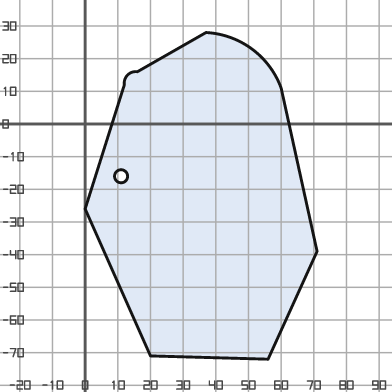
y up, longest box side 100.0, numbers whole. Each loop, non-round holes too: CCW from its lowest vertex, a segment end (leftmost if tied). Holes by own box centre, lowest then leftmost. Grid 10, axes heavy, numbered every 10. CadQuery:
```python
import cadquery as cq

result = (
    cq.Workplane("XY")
    .moveTo(56.0, -72.0)
    .lineTo(71.0, -39.0)
    .lineTo(60.0, 11.0)
    .threePointArc((51.0, 23.0), (37.0, 28.0))
    .lineTo(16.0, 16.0)
    .threePointArc((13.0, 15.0), (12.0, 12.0))
    .lineTo(0.0, -26.0)
    .lineTo(20.0, -71.0)
    .close()
    .moveTo(11.0, -16.0)
    .circle(2.0)
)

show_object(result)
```